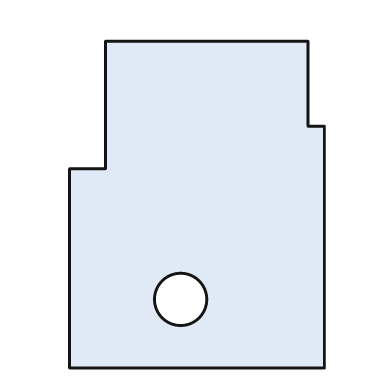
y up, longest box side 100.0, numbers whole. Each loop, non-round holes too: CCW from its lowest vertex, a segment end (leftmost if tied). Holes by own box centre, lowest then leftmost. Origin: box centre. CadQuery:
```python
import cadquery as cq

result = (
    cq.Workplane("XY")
    .moveTo(-39.0, -50.0)
    .lineTo(39.0, -50.0)
    .lineTo(39.0, 24.0)
    .lineTo(34.0, 24.0)
    .lineTo(34.0, 50.0)
    .lineTo(-28.0, 50.0)
    .lineTo(-28.0, 11.0)
    .lineTo(-39.0, 11.0)
    .close()
    .moveTo(-5.0, -29.0)
    .circle(8.0)
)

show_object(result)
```